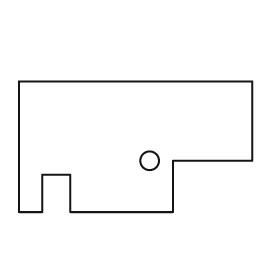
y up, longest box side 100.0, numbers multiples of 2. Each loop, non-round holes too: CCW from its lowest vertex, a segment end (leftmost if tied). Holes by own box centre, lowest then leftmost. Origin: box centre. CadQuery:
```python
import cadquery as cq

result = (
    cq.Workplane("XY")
    .moveTo(-50.0, -28.0)
    .lineTo(-40.0, -28.0)
    .lineTo(-40.0, -12.0)
    .lineTo(-28.0, -12.0)
    .lineTo(-28.0, -28.0)
    .lineTo(16.0, -28.0)
    .lineTo(16.0, -6.0)
    .lineTo(50.0, -6.0)
    .lineTo(50.0, 28.0)
    .lineTo(-50.0, 28.0)
    .close()
    .moveTo(6.0, -6.0)
    .circle(4.0)
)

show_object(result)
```